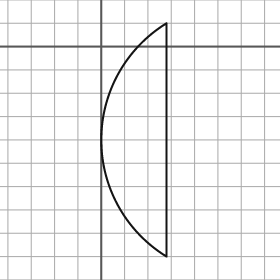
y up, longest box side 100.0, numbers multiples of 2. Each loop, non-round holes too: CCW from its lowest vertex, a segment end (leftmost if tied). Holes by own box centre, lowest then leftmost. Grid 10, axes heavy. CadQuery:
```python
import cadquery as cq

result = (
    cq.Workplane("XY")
    .moveTo(28.0, -90.0)
    .lineTo(28.0, 10.0)
    .threePointArc((0.0, -40.0), (28.0, -90.0))
    .close()
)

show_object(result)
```